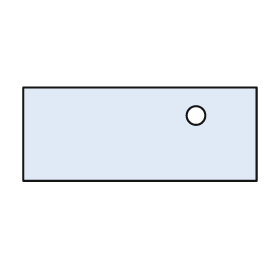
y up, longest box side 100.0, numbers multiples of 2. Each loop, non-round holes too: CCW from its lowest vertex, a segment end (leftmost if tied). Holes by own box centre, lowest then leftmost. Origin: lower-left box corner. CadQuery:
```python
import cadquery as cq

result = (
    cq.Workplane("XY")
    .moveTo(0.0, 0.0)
    .lineTo(100.0, 0.0)
    .lineTo(100.0, 40.0)
    .lineTo(0.0, 40.0)
    .close()
    .moveTo(74.0, 28.0)
    .circle(4.0)
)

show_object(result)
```